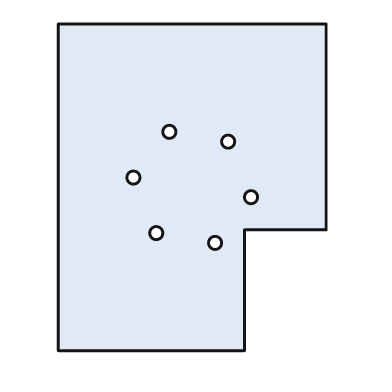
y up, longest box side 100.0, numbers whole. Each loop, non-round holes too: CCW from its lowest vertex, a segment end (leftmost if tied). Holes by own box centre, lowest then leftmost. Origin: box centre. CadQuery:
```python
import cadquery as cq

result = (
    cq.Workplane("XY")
    .moveTo(-41.0, -50.0)
    .lineTo(16.0, -50.0)
    .lineTo(16.0, -13.0)
    .lineTo(41.0, -13.0)
    .lineTo(41.0, 50.0)
    .lineTo(-41.0, 50.0)
    .close()
    .moveTo(7.0, -17.0)
    .circle(2.0)
    .moveTo(-11.0, -14.0)
    .circle(2.0)
    .moveTo(18.0, -3.0)
    .circle(2.0)
    .moveTo(-18.0, 3.0)
    .circle(2.0)
    .moveTo(11.0, 14.0)
    .circle(2.0)
    .moveTo(-7.0, 17.0)
    .circle(2.0)
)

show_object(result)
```